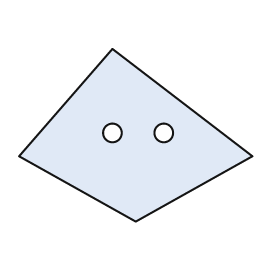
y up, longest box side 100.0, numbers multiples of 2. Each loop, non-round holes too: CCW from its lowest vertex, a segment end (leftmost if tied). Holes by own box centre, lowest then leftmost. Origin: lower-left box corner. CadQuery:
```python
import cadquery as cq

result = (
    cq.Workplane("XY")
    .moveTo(50.0, 0.0)
    .lineTo(100.0, 28.0)
    .lineTo(40.0, 74.0)
    .lineTo(0.0, 28.0)
    .close()
    .moveTo(40.0, 38.0)
    .circle(4.0)
    .moveTo(62.0, 38.0)
    .circle(4.0)
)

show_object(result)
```